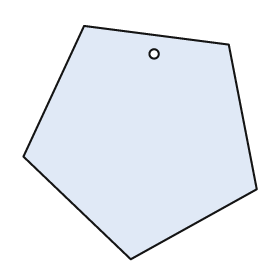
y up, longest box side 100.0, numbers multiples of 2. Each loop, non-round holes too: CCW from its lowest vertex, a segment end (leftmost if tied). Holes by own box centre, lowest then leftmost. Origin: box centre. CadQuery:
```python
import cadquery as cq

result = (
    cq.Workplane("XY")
    .moveTo(-4.0, -50.0)
    .lineTo(50.0, -20.0)
    .lineTo(38.0, 42.0)
    .lineTo(-24.0, 50.0)
    .lineTo(-50.0, -6.0)
    .close()
    .moveTo(6.0, 38.0)
    .circle(2.0)
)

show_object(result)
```